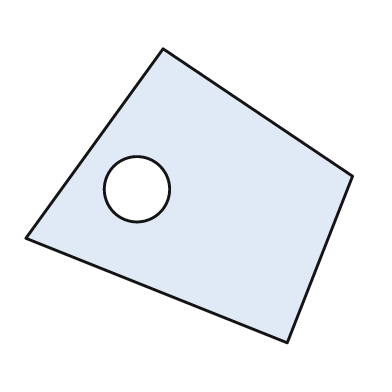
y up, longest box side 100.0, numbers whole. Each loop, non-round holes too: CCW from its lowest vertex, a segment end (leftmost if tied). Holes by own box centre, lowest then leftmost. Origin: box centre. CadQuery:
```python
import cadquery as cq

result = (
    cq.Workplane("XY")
    .moveTo(30.0, -45.0)
    .lineTo(50.0, 6.0)
    .lineTo(-8.0, 45.0)
    .lineTo(-50.0, -13.0)
    .close()
    .moveTo(-16.0, 2.0)
    .circle(10.0)
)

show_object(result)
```